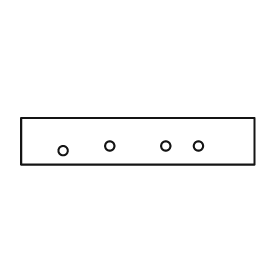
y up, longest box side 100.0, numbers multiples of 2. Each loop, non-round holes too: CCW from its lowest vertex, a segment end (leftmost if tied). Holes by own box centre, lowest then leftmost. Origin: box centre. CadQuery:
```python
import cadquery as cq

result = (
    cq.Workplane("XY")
    .moveTo(-50.0, -10.0)
    .lineTo(50.0, -10.0)
    .lineTo(50.0, 10.0)
    .lineTo(-50.0, 10.0)
    .close()
    .moveTo(-32.0, -4.0)
    .circle(2.0)
    .moveTo(-12.0, -2.0)
    .circle(2.0)
    .moveTo(12.0, -2.0)
    .circle(2.0)
    .moveTo(26.0, -2.0)
    .circle(2.0)
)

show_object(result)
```